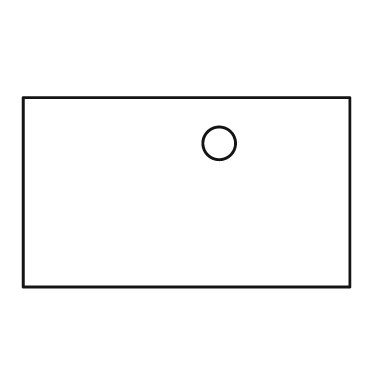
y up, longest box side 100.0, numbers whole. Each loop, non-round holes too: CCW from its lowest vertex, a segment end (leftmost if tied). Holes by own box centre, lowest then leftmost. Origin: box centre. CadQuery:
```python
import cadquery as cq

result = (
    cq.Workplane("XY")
    .moveTo(-50.0, -29.0)
    .lineTo(50.0, -29.0)
    .lineTo(50.0, 29.0)
    .lineTo(-50.0, 29.0)
    .close()
    .moveTo(10.0, 15.0)
    .circle(5.0)
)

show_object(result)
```